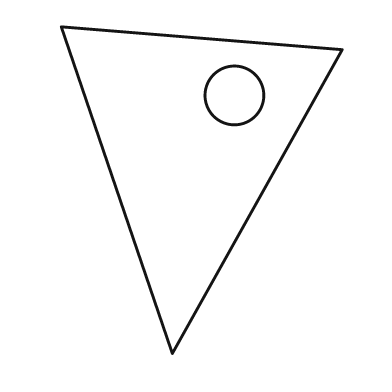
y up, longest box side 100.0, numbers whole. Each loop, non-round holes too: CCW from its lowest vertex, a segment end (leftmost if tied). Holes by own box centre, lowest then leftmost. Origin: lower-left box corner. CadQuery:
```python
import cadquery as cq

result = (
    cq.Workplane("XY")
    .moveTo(34.0, 0.0)
    .lineTo(86.0, 93.0)
    .lineTo(0.0, 100.0)
    .close()
    .moveTo(53.0, 79.0)
    .circle(9.0)
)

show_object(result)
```